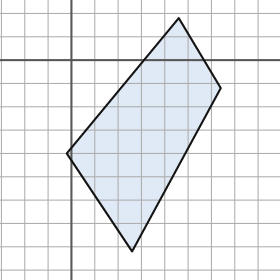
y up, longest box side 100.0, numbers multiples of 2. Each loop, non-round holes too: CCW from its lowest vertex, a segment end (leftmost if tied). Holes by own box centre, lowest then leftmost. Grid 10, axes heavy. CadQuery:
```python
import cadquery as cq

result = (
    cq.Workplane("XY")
    .moveTo(26.0, -82.0)
    .lineTo(64.0, -12.0)
    .lineTo(46.0, 18.0)
    .lineTo(-2.0, -40.0)
    .close()
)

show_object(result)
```